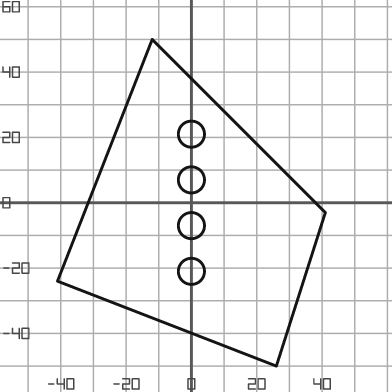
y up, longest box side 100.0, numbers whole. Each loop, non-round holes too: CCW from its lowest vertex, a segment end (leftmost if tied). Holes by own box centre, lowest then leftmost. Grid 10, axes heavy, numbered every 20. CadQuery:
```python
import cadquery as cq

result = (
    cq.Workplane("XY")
    .moveTo(26.0, -50.0)
    .lineTo(41.0, -3.0)
    .lineTo(-12.0, 50.0)
    .lineTo(-41.0, -24.0)
    .close()
    .moveTo(0.0, -21.0)
    .circle(4.0)
    .moveTo(0.0, -7.0)
    .circle(4.0)
    .moveTo(0.0, 7.0)
    .circle(4.0)
    .moveTo(0.0, 21.0)
    .circle(4.0)
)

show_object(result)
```